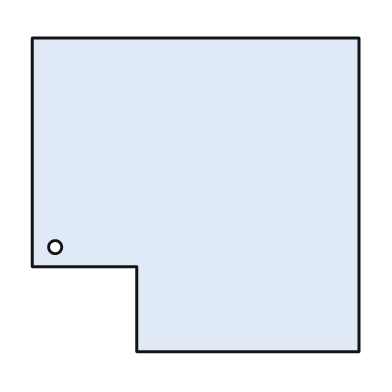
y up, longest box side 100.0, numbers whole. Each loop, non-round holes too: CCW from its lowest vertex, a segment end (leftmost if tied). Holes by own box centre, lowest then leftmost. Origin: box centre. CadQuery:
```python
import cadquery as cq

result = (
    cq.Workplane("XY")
    .moveTo(-18.0, -48.0)
    .lineTo(50.0, -48.0)
    .lineTo(50.0, 48.0)
    .lineTo(-50.0, 48.0)
    .lineTo(-50.0, -22.0)
    .lineTo(-18.0, -22.0)
    .close()
    .moveTo(-43.0, -16.0)
    .circle(2.0)
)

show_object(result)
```